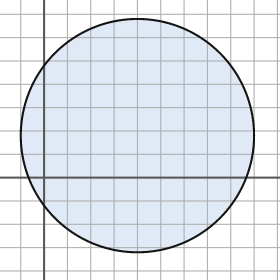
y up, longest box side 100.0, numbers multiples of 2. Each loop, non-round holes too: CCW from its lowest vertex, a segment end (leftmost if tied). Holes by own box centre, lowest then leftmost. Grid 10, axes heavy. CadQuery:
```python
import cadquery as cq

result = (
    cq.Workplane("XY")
    .moveTo(40.0, 18.0)
    .circle(50.0)
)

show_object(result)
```